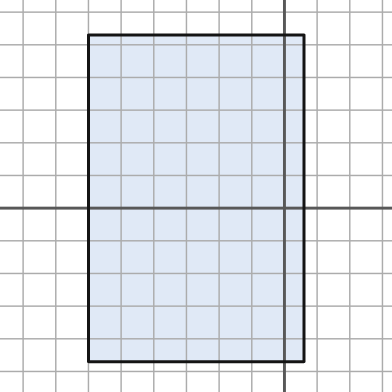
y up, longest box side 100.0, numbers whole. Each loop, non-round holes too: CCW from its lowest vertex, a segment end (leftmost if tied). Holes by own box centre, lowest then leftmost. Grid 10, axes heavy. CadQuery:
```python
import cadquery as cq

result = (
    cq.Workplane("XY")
    .moveTo(-60.0, -47.0)
    .lineTo(6.0, -47.0)
    .lineTo(6.0, 53.0)
    .lineTo(-60.0, 53.0)
    .close()
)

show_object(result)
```